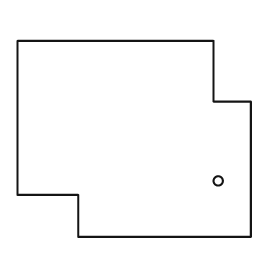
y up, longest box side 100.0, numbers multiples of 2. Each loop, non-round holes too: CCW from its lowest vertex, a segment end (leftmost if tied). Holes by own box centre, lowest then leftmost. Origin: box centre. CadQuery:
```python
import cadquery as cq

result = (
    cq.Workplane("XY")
    .moveTo(-24.0, -42.0)
    .lineTo(50.0, -42.0)
    .lineTo(50.0, 16.0)
    .lineTo(34.0, 16.0)
    .lineTo(34.0, 42.0)
    .lineTo(-50.0, 42.0)
    .lineTo(-50.0, -24.0)
    .lineTo(-24.0, -24.0)
    .close()
    .moveTo(36.0, -18.0)
    .circle(2.0)
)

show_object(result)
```